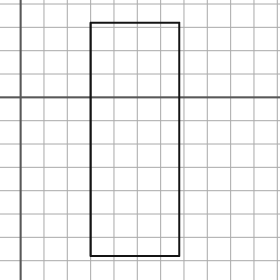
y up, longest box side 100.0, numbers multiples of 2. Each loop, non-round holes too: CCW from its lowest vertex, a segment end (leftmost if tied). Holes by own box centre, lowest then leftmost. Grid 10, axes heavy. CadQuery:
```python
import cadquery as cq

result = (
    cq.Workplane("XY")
    .moveTo(30.0, -68.0)
    .lineTo(68.0, -68.0)
    .lineTo(68.0, 32.0)
    .lineTo(30.0, 32.0)
    .close()
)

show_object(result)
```